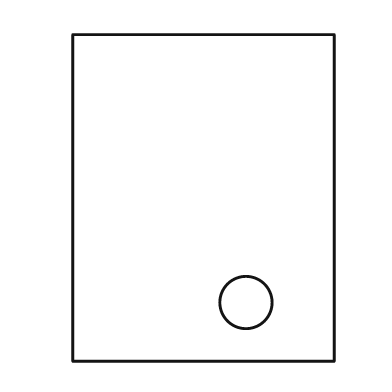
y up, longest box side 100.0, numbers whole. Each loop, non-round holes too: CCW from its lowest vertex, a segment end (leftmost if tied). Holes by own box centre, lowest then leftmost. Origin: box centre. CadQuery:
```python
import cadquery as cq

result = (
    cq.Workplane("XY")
    .moveTo(-40.0, -50.0)
    .lineTo(40.0, -50.0)
    .lineTo(40.0, 50.0)
    .lineTo(-40.0, 50.0)
    .close()
    .moveTo(13.0, -32.0)
    .circle(8.0)
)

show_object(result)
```